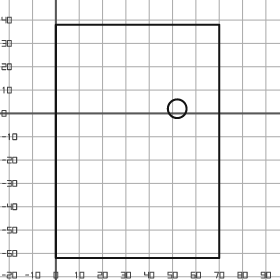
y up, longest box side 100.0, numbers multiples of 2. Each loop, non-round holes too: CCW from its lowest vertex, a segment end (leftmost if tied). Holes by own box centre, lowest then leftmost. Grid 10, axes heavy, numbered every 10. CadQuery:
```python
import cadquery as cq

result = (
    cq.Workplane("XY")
    .moveTo(0.0, -62.0)
    .lineTo(70.0, -62.0)
    .lineTo(70.0, 38.0)
    .lineTo(0.0, 38.0)
    .close()
    .moveTo(52.0, 2.0)
    .circle(4.0)
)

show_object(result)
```